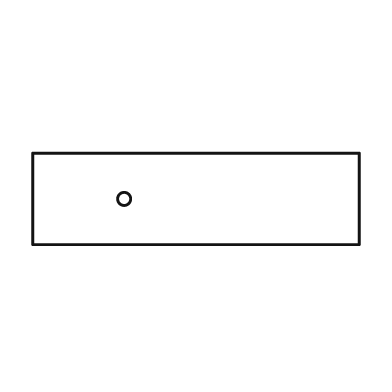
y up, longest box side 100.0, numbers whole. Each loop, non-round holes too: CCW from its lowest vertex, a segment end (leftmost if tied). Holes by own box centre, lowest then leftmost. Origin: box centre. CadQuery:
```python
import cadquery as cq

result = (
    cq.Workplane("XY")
    .moveTo(-50.0, -14.0)
    .lineTo(50.0, -14.0)
    .lineTo(50.0, 14.0)
    .lineTo(-50.0, 14.0)
    .close()
    .moveTo(-22.0, 0.0)
    .circle(2.0)
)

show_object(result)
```